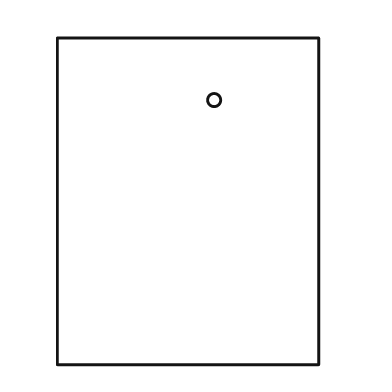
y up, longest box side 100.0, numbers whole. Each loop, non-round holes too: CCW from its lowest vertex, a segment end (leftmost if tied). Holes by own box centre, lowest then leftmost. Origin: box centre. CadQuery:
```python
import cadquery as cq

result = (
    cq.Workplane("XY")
    .moveTo(-40.0, -50.0)
    .lineTo(40.0, -50.0)
    .lineTo(40.0, 50.0)
    .lineTo(-40.0, 50.0)
    .close()
    .moveTo(8.0, 31.0)
    .circle(2.0)
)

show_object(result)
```